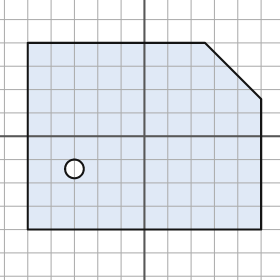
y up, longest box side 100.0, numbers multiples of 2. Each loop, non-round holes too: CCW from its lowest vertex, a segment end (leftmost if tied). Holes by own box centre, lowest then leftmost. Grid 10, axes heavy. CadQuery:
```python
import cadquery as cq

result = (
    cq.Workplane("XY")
    .moveTo(-50.0, -40.0)
    .lineTo(50.0, -40.0)
    .lineTo(50.0, 16.0)
    .lineTo(26.0, 40.0)
    .lineTo(-50.0, 40.0)
    .close()
    .moveTo(-30.0, -14.0)
    .circle(4.0)
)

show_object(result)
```